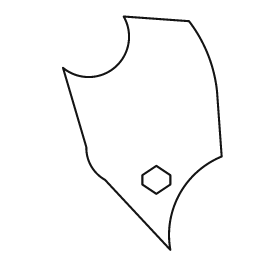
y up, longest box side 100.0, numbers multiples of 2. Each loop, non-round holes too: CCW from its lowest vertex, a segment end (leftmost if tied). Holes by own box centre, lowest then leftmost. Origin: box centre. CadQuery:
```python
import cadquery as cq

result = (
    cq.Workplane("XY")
    .moveTo(12.0, -50.0)
    .threePointArc((16.0, -26.0), (34.0, -10.0))
    .lineTo(32.0, 18.0)
    .threePointArc((28.0, 34.0), (20.0, 48.0))
    .lineTo(-8.0, 50.0)
    .threePointArc((-12.0, 28.0), (-34.0, 28.0))
    .lineTo(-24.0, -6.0)
    .threePointArc((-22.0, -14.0), (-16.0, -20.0))
    .close()
    .moveTo(6.0, -26.0)
    .lineTo(12.0, -22.0)
    .lineTo(12.0, -18.0)
    .lineTo(6.0, -14.0)
    .lineTo(0.0, -18.0)
    .lineTo(0.0, -22.0)
    .close()
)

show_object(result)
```